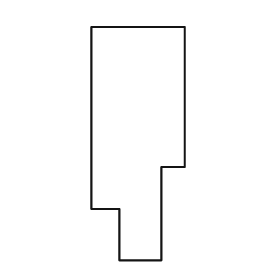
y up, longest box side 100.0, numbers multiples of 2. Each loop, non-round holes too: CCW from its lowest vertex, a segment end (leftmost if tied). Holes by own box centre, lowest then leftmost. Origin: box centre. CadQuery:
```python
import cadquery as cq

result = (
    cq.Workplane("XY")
    .moveTo(-8.0, -50.0)
    .lineTo(10.0, -50.0)
    .lineTo(10.0, -10.0)
    .lineTo(20.0, -10.0)
    .lineTo(20.0, 50.0)
    .lineTo(-20.0, 50.0)
    .lineTo(-20.0, -28.0)
    .lineTo(-8.0, -28.0)
    .close()
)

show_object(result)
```